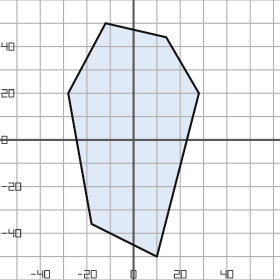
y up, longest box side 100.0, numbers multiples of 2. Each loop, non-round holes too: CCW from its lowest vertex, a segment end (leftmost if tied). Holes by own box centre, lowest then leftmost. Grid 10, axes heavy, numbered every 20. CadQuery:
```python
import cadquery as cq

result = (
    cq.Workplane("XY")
    .moveTo(10.0, -50.0)
    .lineTo(28.0, 20.0)
    .lineTo(14.0, 44.0)
    .lineTo(-12.0, 50.0)
    .lineTo(-28.0, 20.0)
    .lineTo(-18.0, -36.0)
    .close()
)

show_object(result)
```